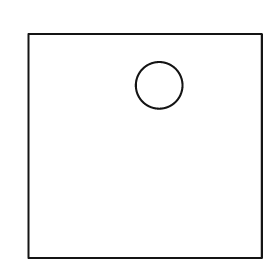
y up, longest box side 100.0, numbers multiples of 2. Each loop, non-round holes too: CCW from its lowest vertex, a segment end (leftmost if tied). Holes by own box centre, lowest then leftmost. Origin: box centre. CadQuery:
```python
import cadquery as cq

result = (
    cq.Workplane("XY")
    .moveTo(-50.0, -48.0)
    .lineTo(50.0, -48.0)
    .lineTo(50.0, 48.0)
    .lineTo(-50.0, 48.0)
    .close()
    .moveTo(6.0, 26.0)
    .circle(10.0)
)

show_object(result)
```